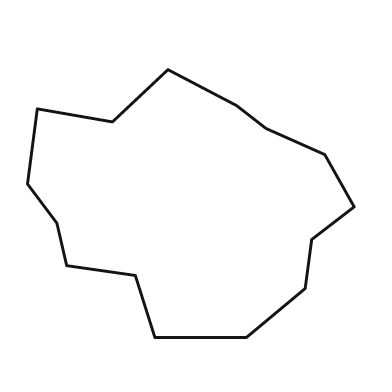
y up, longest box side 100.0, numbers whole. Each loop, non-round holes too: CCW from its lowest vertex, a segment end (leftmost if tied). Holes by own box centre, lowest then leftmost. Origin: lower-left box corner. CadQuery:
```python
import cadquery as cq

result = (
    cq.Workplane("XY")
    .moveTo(39.0, 0.0)
    .lineTo(67.0, 0.0)
    .lineTo(85.0, 15.0)
    .lineTo(87.0, 30.0)
    .lineTo(100.0, 40.0)
    .lineTo(91.0, 56.0)
    .lineTo(73.0, 64.0)
    .lineTo(64.0, 71.0)
    .lineTo(43.0, 82.0)
    .lineTo(26.0, 66.0)
    .lineTo(3.0, 70.0)
    .lineTo(0.0, 47.0)
    .lineTo(9.0, 35.0)
    .lineTo(12.0, 22.0)
    .lineTo(33.0, 19.0)
    .close()
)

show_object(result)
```